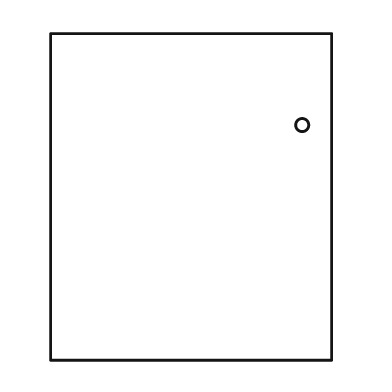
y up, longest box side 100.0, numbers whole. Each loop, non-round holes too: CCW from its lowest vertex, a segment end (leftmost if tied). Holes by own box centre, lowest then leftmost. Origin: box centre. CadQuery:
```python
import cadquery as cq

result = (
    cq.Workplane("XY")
    .moveTo(-43.0, -50.0)
    .lineTo(43.0, -50.0)
    .lineTo(43.0, 50.0)
    .lineTo(-43.0, 50.0)
    .close()
    .moveTo(34.0, 22.0)
    .circle(2.0)
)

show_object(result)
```